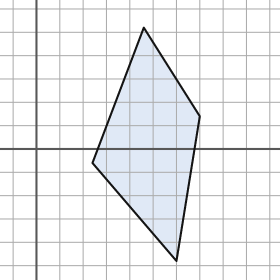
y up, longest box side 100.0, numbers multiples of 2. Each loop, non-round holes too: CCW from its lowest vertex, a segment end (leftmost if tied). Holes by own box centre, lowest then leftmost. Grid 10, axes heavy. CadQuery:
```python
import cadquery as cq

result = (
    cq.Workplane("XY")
    .moveTo(60.0, -48.0)
    .lineTo(70.0, 14.0)
    .lineTo(46.0, 52.0)
    .lineTo(24.0, -6.0)
    .close()
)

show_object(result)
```